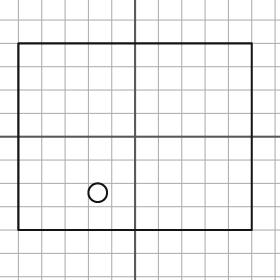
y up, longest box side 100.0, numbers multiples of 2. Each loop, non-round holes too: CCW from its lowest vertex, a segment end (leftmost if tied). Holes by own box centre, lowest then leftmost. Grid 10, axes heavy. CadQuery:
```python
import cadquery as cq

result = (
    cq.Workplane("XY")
    .moveTo(-50.0, -40.0)
    .lineTo(50.0, -40.0)
    .lineTo(50.0, 40.0)
    .lineTo(-50.0, 40.0)
    .close()
    .moveTo(-16.0, -24.0)
    .circle(4.0)
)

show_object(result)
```